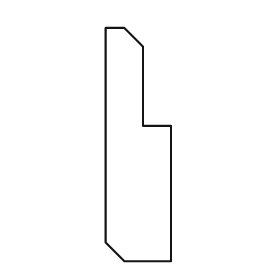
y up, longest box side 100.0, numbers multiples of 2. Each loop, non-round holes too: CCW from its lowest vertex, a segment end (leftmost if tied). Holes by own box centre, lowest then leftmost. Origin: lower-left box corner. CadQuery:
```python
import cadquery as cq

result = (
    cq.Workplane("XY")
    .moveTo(8.0, 0.0)
    .lineTo(28.0, 0.0)
    .lineTo(28.0, 58.0)
    .lineTo(16.0, 58.0)
    .lineTo(16.0, 92.0)
    .lineTo(8.0, 100.0)
    .lineTo(0.0, 100.0)
    .lineTo(0.0, 8.0)
    .close()
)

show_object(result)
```